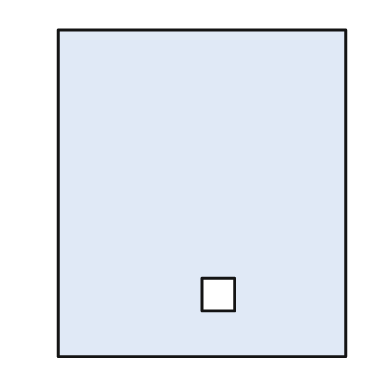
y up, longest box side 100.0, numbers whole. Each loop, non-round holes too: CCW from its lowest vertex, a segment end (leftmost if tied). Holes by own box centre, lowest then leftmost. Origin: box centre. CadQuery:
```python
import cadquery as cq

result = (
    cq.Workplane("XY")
    .moveTo(-44.0, -50.0)
    .lineTo(44.0, -50.0)
    .lineTo(44.0, 50.0)
    .lineTo(-44.0, 50.0)
    .close()
    .moveTo(0.0, -36.0)
    .lineTo(10.0, -36.0)
    .lineTo(10.0, -26.0)
    .lineTo(0.0, -26.0)
    .close()
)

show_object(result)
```